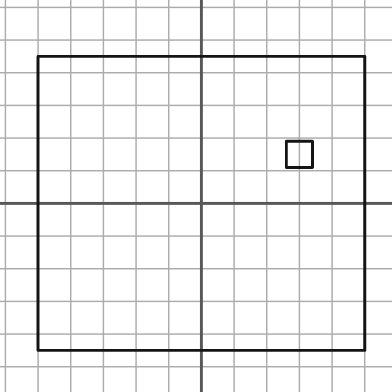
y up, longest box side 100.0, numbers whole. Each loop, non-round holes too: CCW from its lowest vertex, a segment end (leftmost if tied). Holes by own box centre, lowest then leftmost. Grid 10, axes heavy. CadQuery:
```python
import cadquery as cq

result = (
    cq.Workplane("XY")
    .moveTo(-50.0, -45.0)
    .lineTo(50.0, -45.0)
    .lineTo(50.0, 45.0)
    .lineTo(-50.0, 45.0)
    .close()
    .moveTo(26.0, 11.0)
    .lineTo(34.0, 11.0)
    .lineTo(34.0, 19.0)
    .lineTo(26.0, 19.0)
    .close()
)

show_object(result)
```